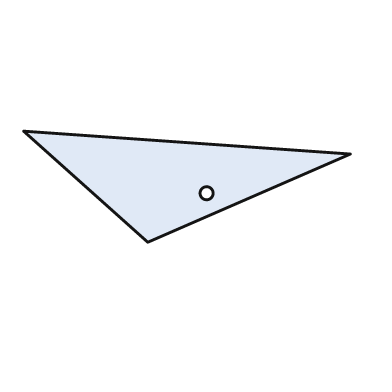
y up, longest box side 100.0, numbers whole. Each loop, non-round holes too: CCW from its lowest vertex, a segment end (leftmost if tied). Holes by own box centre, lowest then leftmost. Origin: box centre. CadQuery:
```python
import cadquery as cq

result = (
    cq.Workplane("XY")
    .moveTo(-12.0, -17.0)
    .lineTo(50.0, 10.0)
    .lineTo(-50.0, 17.0)
    .close()
    .moveTo(6.0, -2.0)
    .circle(2.0)
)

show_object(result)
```